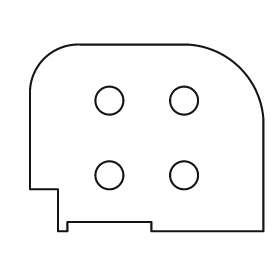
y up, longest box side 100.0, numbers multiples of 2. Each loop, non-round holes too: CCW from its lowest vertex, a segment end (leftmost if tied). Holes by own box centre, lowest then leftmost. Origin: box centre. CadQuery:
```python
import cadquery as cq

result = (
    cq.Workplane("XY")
    .moveTo(-38.0, -40.0)
    .lineTo(-34.0, -40.0)
    .lineTo(-34.0, -36.0)
    .lineTo(2.0, -36.0)
    .lineTo(2.0, -40.0)
    .lineTo(50.0, -40.0)
    .lineTo(50.0, 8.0)
    .threePointArc((40.0, 30.0), (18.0, 40.0))
    .lineTo(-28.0, 40.0)
    .threePointArc((-44.0, 34.0), (-50.0, 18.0))
    .lineTo(-50.0, -22.0)
    .lineTo(-38.0, -22.0)
    .close()
    .moveTo(-16.0, -16.0)
    .circle(6.0)
    .moveTo(16.0, -16.0)
    .circle(6.0)
    .moveTo(-16.0, 16.0)
    .circle(6.0)
    .moveTo(16.0, 16.0)
    .circle(6.0)
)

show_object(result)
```